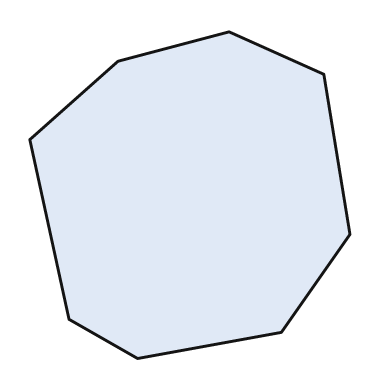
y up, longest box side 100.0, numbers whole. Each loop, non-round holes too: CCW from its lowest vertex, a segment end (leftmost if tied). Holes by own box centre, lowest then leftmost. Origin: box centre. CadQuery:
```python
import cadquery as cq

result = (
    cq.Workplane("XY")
    .moveTo(-16.0, -50.0)
    .lineTo(28.0, -42.0)
    .lineTo(49.0, -12.0)
    .lineTo(41.0, 37.0)
    .lineTo(12.0, 50.0)
    .lineTo(-22.0, 41.0)
    .lineTo(-49.0, 17.0)
    .lineTo(-37.0, -38.0)
    .close()
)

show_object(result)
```